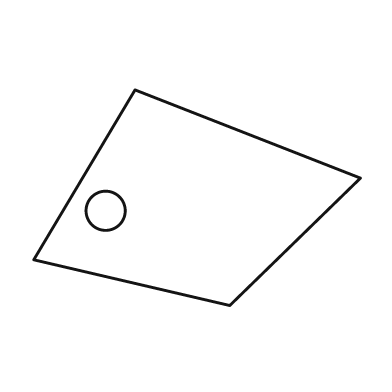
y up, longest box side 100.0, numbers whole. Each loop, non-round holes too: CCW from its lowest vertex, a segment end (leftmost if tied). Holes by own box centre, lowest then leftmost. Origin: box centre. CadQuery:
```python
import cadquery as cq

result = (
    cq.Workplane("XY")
    .moveTo(10.0, -33.0)
    .lineTo(50.0, 6.0)
    .lineTo(-19.0, 33.0)
    .lineTo(-50.0, -19.0)
    .close()
    .moveTo(-28.0, -4.0)
    .circle(6.0)
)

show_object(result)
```